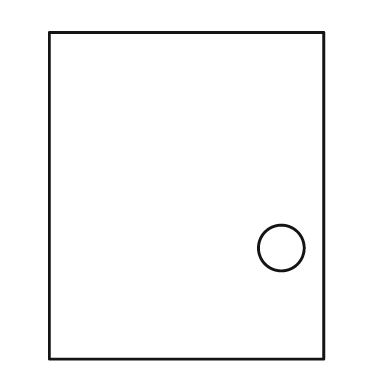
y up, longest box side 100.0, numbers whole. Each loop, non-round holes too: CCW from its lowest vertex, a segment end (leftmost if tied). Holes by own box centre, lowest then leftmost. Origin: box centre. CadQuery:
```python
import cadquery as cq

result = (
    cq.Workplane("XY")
    .moveTo(-42.0, -50.0)
    .lineTo(42.0, -50.0)
    .lineTo(42.0, 50.0)
    .lineTo(-42.0, 50.0)
    .close()
    .moveTo(29.0, -16.0)
    .circle(7.0)
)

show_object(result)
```